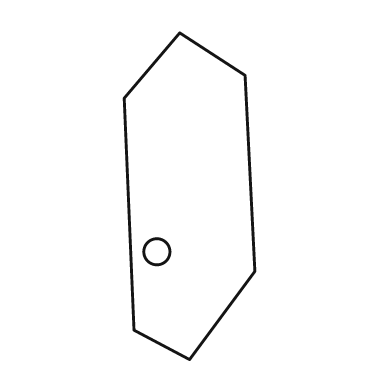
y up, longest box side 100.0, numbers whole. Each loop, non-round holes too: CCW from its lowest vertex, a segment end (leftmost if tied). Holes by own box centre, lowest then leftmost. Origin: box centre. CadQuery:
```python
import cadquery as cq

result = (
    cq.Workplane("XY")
    .moveTo(0.0, -50.0)
    .lineTo(20.0, -23.0)
    .lineTo(17.0, 37.0)
    .lineTo(-3.0, 50.0)
    .lineTo(-20.0, 30.0)
    .lineTo(-17.0, -41.0)
    .close()
    .moveTo(-10.0, -17.0)
    .circle(4.0)
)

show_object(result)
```